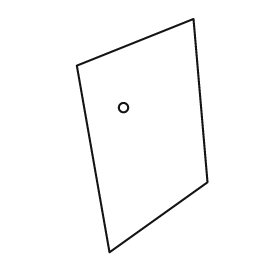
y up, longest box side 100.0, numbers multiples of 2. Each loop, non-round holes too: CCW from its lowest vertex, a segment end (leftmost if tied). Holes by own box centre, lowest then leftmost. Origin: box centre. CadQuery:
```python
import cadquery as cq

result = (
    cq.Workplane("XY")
    .moveTo(-14.0, -50.0)
    .lineTo(28.0, -20.0)
    .lineTo(22.0, 50.0)
    .lineTo(-28.0, 30.0)
    .close()
    .moveTo(-8.0, 12.0)
    .circle(2.0)
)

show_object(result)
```